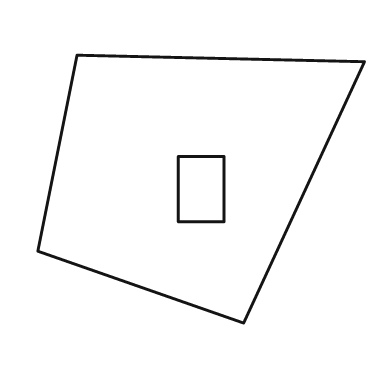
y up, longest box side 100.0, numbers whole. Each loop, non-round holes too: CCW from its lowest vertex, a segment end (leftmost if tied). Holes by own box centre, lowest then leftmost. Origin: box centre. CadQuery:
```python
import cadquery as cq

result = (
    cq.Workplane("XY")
    .moveTo(13.0, -41.0)
    .lineTo(50.0, 39.0)
    .lineTo(-38.0, 41.0)
    .lineTo(-50.0, -19.0)
    .close()
    .moveTo(-7.0, -10.0)
    .lineTo(7.0, -10.0)
    .lineTo(7.0, 10.0)
    .lineTo(-7.0, 10.0)
    .close()
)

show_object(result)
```